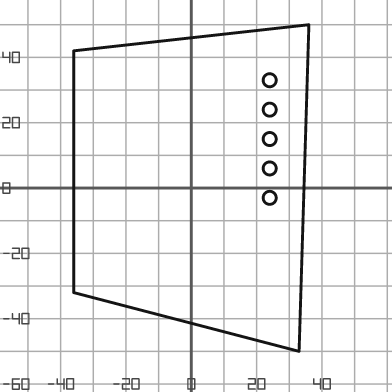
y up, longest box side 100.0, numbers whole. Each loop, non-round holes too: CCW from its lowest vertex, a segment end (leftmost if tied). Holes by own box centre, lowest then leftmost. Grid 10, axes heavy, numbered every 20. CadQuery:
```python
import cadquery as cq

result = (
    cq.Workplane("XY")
    .moveTo(33.0, -50.0)
    .lineTo(36.0, 50.0)
    .lineTo(-36.0, 42.0)
    .lineTo(-36.0, -32.0)
    .close()
    .moveTo(24.0, -3.0)
    .circle(2.0)
    .moveTo(24.0, 6.0)
    .circle(2.0)
    .moveTo(24.0, 15.0)
    .circle(2.0)
    .moveTo(24.0, 24.0)
    .circle(2.0)
    .moveTo(24.0, 33.0)
    .circle(2.0)
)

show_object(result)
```